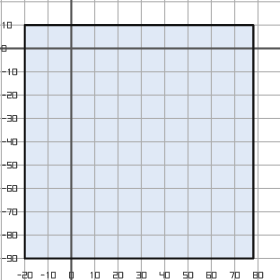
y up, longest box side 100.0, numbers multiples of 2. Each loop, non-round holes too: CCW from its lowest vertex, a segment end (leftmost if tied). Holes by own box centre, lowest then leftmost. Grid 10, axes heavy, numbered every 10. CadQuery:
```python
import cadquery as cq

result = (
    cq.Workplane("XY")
    .moveTo(-20.0, -90.0)
    .lineTo(78.0, -90.0)
    .lineTo(78.0, 10.0)
    .lineTo(-20.0, 10.0)
    .close()
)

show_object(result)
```